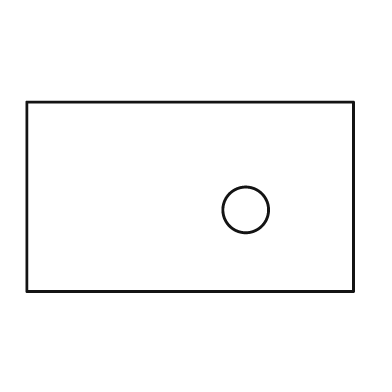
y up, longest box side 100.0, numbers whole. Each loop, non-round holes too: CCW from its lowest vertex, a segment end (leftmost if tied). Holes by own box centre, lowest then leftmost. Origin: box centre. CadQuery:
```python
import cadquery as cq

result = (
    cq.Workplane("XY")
    .moveTo(-50.0, -29.0)
    .lineTo(50.0, -29.0)
    .lineTo(50.0, 29.0)
    .lineTo(-50.0, 29.0)
    .close()
    .moveTo(17.0, -4.0)
    .circle(7.0)
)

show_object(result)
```